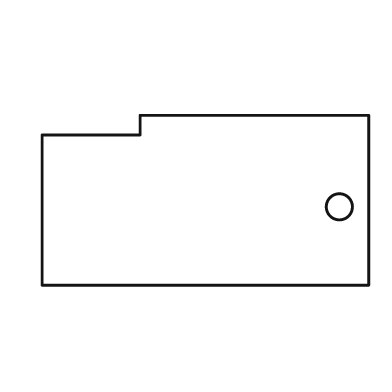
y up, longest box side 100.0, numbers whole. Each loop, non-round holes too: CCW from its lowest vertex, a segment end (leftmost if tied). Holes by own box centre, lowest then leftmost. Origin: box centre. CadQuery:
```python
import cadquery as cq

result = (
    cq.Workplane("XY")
    .moveTo(-50.0, -26.0)
    .lineTo(50.0, -26.0)
    .lineTo(50.0, 26.0)
    .lineTo(-20.0, 26.0)
    .lineTo(-20.0, 20.0)
    .lineTo(-50.0, 20.0)
    .close()
    .moveTo(41.0, -2.0)
    .circle(4.0)
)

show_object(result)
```